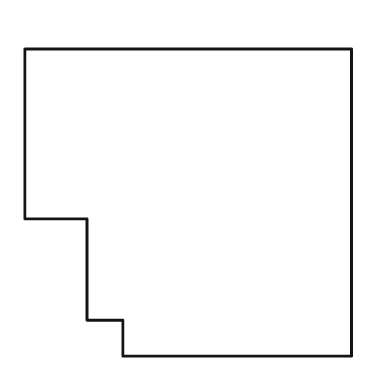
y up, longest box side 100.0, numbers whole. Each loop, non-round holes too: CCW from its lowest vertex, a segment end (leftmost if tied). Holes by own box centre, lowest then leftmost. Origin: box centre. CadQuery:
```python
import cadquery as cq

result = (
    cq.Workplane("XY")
    .moveTo(-20.0, -47.0)
    .lineTo(50.0, -47.0)
    .lineTo(50.0, 47.0)
    .lineTo(-50.0, 47.0)
    .lineTo(-50.0, -5.0)
    .lineTo(-31.0, -5.0)
    .lineTo(-31.0, -36.0)
    .lineTo(-20.0, -36.0)
    .close()
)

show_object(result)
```